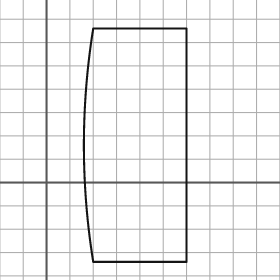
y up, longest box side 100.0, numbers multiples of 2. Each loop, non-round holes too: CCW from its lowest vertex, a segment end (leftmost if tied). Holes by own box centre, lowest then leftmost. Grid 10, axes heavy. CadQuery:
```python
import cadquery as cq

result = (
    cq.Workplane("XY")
    .moveTo(20.0, -34.0)
    .lineTo(60.0, -34.0)
    .lineTo(60.0, 66.0)
    .lineTo(20.0, 66.0)
    .threePointArc((16.0, 16.0), (20.0, -34.0))
    .close()
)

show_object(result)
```